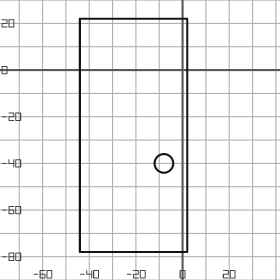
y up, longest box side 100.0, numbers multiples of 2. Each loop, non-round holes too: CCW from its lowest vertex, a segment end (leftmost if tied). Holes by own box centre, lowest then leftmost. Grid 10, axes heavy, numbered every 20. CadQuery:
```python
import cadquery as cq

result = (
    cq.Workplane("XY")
    .moveTo(-44.0, -78.0)
    .lineTo(2.0, -78.0)
    .lineTo(2.0, 22.0)
    .lineTo(-44.0, 22.0)
    .close()
    .moveTo(-8.0, -40.0)
    .circle(4.0)
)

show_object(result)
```